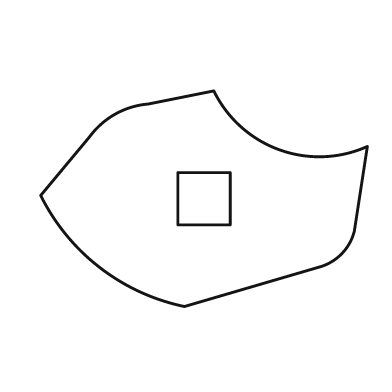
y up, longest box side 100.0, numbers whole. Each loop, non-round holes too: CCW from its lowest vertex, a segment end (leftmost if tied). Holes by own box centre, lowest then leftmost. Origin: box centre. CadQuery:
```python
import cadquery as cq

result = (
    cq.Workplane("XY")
    .moveTo(-6.0, -33.0)
    .lineTo(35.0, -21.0)
    .threePointArc((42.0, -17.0), (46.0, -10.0))
    .lineTo(50.0, 16.0)
    .threePointArc((23.0, 15.0), (3.0, 33.0))
    .lineTo(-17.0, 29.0)
    .threePointArc((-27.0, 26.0), (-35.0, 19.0))
    .lineTo(-50.0, 1.0)
    .threePointArc((-32.0, -21.0), (-6.0, -33.0))
    .close()
    .moveTo(-8.0, -8.0)
    .lineTo(8.0, -8.0)
    .lineTo(8.0, 8.0)
    .lineTo(-8.0, 8.0)
    .close()
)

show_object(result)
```